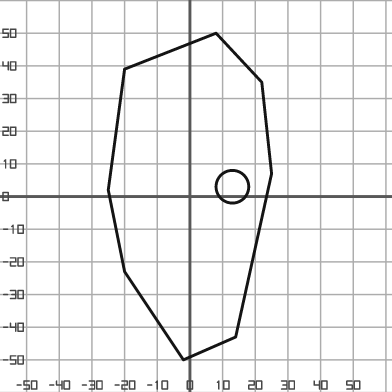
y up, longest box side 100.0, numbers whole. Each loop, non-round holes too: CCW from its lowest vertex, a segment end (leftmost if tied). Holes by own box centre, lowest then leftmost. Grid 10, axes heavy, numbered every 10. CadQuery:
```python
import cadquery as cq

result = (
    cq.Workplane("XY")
    .moveTo(-2.0, -50.0)
    .lineTo(14.0, -43.0)
    .lineTo(25.0, 7.0)
    .lineTo(22.0, 35.0)
    .lineTo(8.0, 50.0)
    .lineTo(-20.0, 39.0)
    .lineTo(-25.0, 2.0)
    .lineTo(-20.0, -23.0)
    .close()
    .moveTo(13.0, 3.0)
    .circle(5.0)
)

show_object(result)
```